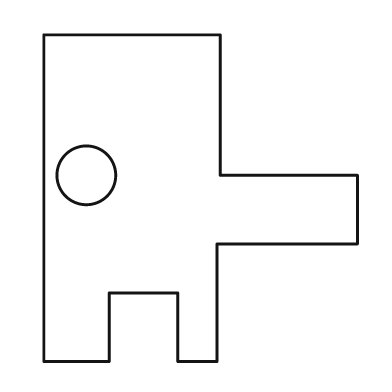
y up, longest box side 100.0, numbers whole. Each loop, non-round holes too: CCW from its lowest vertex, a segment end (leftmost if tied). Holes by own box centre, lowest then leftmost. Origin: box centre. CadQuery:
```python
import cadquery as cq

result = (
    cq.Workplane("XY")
    .moveTo(-48.0, -50.0)
    .lineTo(-28.0, -50.0)
    .lineTo(-28.0, -29.0)
    .lineTo(-7.0, -29.0)
    .lineTo(-7.0, -50.0)
    .lineTo(5.0, -50.0)
    .lineTo(5.0, -14.0)
    .lineTo(48.0, -14.0)
    .lineTo(48.0, 7.0)
    .lineTo(6.0, 7.0)
    .lineTo(6.0, 50.0)
    .lineTo(-48.0, 50.0)
    .close()
    .moveTo(-35.0, 7.0)
    .circle(9.0)
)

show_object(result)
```